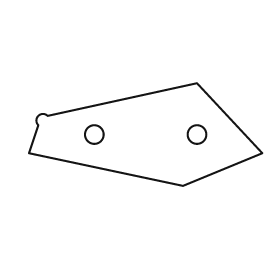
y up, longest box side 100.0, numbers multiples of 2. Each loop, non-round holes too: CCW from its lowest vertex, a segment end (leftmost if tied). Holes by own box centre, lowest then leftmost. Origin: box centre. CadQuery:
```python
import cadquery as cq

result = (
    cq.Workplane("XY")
    .moveTo(16.0, -22.0)
    .lineTo(50.0, -8.0)
    .lineTo(22.0, 22.0)
    .lineTo(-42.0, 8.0)
    .threePointArc((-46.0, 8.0), (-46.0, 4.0))
    .lineTo(-50.0, -8.0)
    .close()
    .moveTo(-22.0, 0.0)
    .circle(4.0)
    .moveTo(22.0, 0.0)
    .circle(4.0)
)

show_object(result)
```